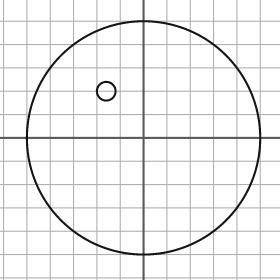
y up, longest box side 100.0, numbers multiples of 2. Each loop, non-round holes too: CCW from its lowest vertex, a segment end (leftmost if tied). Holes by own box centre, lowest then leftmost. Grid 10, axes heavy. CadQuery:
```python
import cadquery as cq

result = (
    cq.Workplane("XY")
    .moveTo(0.0, 0.0)
    .circle(50.0)
    .moveTo(-16.0, 20.0)
    .circle(4.0)
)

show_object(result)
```